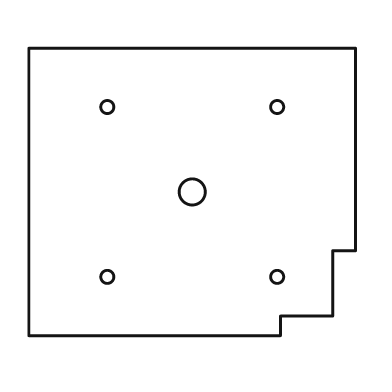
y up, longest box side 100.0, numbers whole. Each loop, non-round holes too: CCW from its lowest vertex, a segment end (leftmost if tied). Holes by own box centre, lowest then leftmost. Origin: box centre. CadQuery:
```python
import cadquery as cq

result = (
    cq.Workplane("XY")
    .moveTo(-50.0, -44.0)
    .lineTo(27.0, -44.0)
    .lineTo(27.0, -38.0)
    .lineTo(43.0, -38.0)
    .lineTo(43.0, -18.0)
    .lineTo(50.0, -18.0)
    .lineTo(50.0, 44.0)
    .lineTo(-50.0, 44.0)
    .close()
    .moveTo(-26.0, -26.0)
    .circle(2.0)
    .moveTo(26.0, -26.0)
    .circle(2.0)
    .moveTo(0.0, 0.0)
    .circle(4.0)
    .moveTo(-26.0, 26.0)
    .circle(2.0)
    .moveTo(26.0, 26.0)
    .circle(2.0)
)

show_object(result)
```